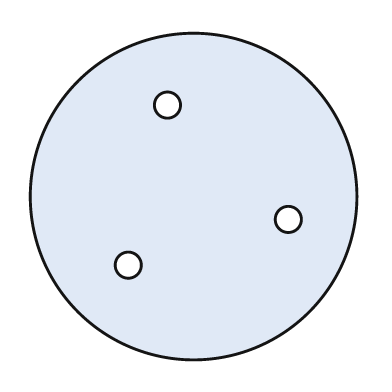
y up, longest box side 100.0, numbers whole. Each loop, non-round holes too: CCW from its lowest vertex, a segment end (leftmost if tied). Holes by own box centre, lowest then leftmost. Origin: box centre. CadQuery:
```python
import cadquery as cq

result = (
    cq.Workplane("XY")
    .moveTo(0.0, 0.0)
    .circle(50.0)
    .moveTo(-20.0, -21.0)
    .circle(4.0)
    .moveTo(29.0, -7.0)
    .circle(4.0)
    .moveTo(-8.0, 28.0)
    .circle(4.0)
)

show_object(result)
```